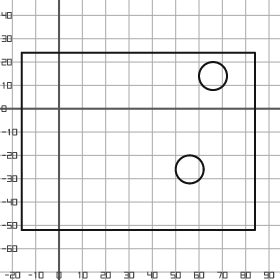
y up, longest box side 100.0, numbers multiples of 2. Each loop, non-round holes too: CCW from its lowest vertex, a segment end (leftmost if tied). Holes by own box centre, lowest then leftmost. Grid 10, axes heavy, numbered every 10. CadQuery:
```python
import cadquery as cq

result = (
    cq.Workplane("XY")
    .moveTo(-16.0, -52.0)
    .lineTo(84.0, -52.0)
    .lineTo(84.0, 24.0)
    .lineTo(-16.0, 24.0)
    .close()
    .moveTo(56.0, -26.0)
    .circle(6.0)
    .moveTo(66.0, 14.0)
    .circle(6.0)
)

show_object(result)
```